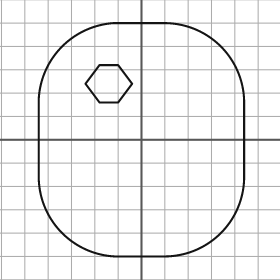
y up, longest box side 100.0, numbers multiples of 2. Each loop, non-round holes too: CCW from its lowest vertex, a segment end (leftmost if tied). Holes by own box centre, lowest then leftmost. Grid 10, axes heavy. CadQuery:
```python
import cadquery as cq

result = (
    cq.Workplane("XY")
    .moveTo(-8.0, -50.0)
    .lineTo(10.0, -50.0)
    .threePointArc((34.0, -40.0), (44.0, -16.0))
    .lineTo(44.0, 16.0)
    .threePointArc((34.0, 40.0), (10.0, 50.0))
    .lineTo(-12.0, 50.0)
    .threePointArc((-34.0, 40.0), (-44.0, 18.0))
    .lineTo(-44.0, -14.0)
    .threePointArc((-34.0, -40.0), (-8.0, -50.0))
    .close()
    .moveTo(-18.0, 16.0)
    .lineTo(-10.0, 16.0)
    .lineTo(-4.0, 24.0)
    .lineTo(-10.0, 32.0)
    .lineTo(-18.0, 32.0)
    .lineTo(-24.0, 24.0)
    .close()
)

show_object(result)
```